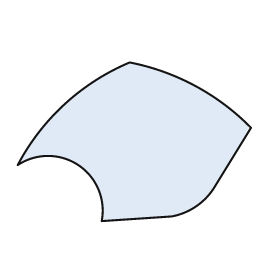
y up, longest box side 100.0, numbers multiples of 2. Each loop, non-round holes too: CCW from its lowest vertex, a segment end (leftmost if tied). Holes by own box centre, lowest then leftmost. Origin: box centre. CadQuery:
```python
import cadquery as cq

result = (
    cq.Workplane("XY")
    .moveTo(-14.0, -34.0)
    .lineTo(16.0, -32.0)
    .threePointArc((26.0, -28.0), (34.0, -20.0))
    .lineTo(50.0, 6.0)
    .threePointArc((26.0, 24.0), (-2.0, 34.0))
    .threePointArc((-30.0, 16.0), (-50.0, -10.0))
    .threePointArc((-24.0, -10.0), (-14.0, -34.0))
    .close()
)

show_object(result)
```